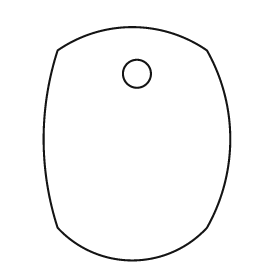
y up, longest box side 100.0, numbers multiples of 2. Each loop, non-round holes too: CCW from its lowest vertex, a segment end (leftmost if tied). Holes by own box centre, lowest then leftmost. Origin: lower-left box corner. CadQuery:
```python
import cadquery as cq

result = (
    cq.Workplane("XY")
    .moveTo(6.0, 14.0)
    .threePointArc((38.0, 0.0), (70.0, 14.0))
    .threePointArc((80.0, 52.0), (70.0, 90.0))
    .threePointArc((38.0, 100.0), (6.0, 90.0))
    .threePointArc((0.0, 52.0), (6.0, 14.0))
    .close()
    .moveTo(40.0, 80.0)
    .circle(6.0)
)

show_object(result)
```